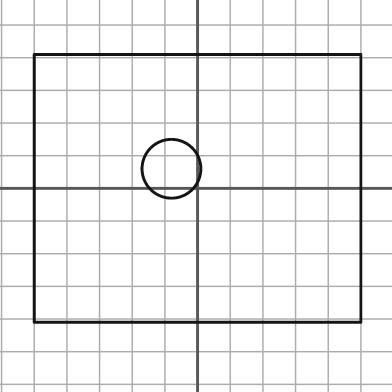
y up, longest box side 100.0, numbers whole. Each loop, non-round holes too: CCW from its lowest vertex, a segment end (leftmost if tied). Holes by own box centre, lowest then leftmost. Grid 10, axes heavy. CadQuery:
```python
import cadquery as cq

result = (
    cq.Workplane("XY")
    .moveTo(-50.0, -41.0)
    .lineTo(50.0, -41.0)
    .lineTo(50.0, 41.0)
    .lineTo(-50.0, 41.0)
    .close()
    .moveTo(-8.0, 6.0)
    .circle(9.0)
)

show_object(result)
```